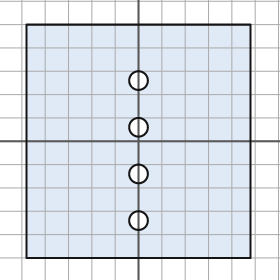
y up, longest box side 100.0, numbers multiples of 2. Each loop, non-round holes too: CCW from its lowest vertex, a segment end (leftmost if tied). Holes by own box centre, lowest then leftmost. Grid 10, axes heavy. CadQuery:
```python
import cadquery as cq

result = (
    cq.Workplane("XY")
    .moveTo(-48.0, -50.0)
    .lineTo(48.0, -50.0)
    .lineTo(48.0, 50.0)
    .lineTo(-48.0, 50.0)
    .close()
    .moveTo(0.0, -34.0)
    .circle(4.0)
    .moveTo(0.0, -14.0)
    .circle(4.0)
    .moveTo(0.0, 6.0)
    .circle(4.0)
    .moveTo(0.0, 26.0)
    .circle(4.0)
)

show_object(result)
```